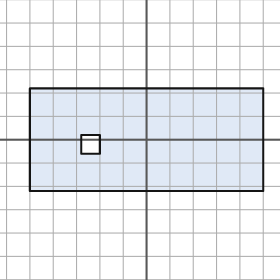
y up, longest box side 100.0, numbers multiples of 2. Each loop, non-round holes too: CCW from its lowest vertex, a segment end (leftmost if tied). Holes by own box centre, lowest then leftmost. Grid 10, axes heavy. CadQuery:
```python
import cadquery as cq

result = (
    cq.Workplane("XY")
    .moveTo(-50.0, -22.0)
    .lineTo(50.0, -22.0)
    .lineTo(50.0, 22.0)
    .lineTo(-50.0, 22.0)
    .close()
    .moveTo(-28.0, -6.0)
    .lineTo(-20.0, -6.0)
    .lineTo(-20.0, 2.0)
    .lineTo(-28.0, 2.0)
    .close()
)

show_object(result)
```